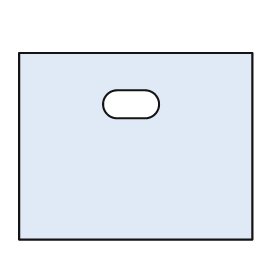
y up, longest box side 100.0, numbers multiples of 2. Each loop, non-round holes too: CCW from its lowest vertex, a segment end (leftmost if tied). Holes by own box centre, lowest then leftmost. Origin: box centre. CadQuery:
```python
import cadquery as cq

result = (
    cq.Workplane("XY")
    .moveTo(-50.0, -40.0)
    .lineTo(50.0, -40.0)
    .lineTo(50.0, 40.0)
    .lineTo(-50.0, 40.0)
    .close()
    .moveTo(-8.0, 12.0)
    .lineTo(4.0, 12.0)
    .threePointArc((10.0, 18.0), (4.0, 24.0))
    .lineTo(-8.0, 24.0)
    .threePointArc((-14.0, 18.0), (-8.0, 12.0))
    .close()
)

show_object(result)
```